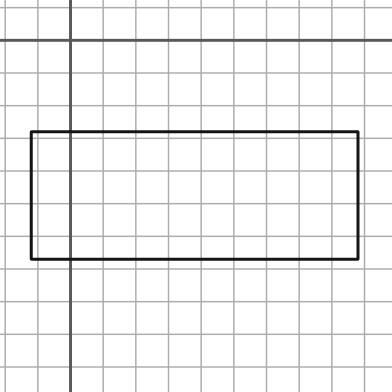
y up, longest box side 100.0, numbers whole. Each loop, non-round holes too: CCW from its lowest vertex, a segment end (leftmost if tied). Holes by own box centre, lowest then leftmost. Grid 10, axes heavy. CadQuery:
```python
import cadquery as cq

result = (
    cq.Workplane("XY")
    .moveTo(-12.0, -67.0)
    .lineTo(88.0, -67.0)
    .lineTo(88.0, -28.0)
    .lineTo(-12.0, -28.0)
    .close()
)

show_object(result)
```